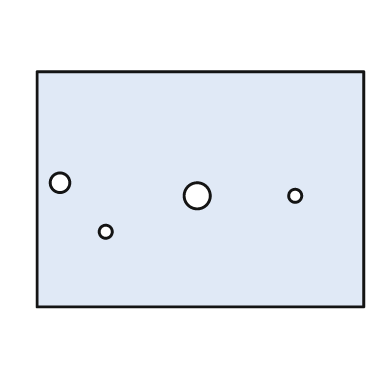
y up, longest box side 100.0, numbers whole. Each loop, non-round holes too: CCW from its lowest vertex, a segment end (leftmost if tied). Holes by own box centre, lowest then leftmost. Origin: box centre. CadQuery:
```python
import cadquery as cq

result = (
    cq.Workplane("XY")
    .moveTo(-50.0, -36.0)
    .lineTo(50.0, -36.0)
    .lineTo(50.0, 36.0)
    .lineTo(-50.0, 36.0)
    .close()
    .moveTo(-29.0, -13.0)
    .circle(2.0)
    .moveTo(-1.0, -2.0)
    .circle(4.0)
    .moveTo(29.0, -2.0)
    .circle(2.0)
    .moveTo(-43.0, 2.0)
    .circle(3.0)
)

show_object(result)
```